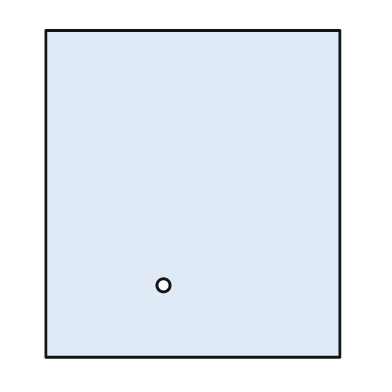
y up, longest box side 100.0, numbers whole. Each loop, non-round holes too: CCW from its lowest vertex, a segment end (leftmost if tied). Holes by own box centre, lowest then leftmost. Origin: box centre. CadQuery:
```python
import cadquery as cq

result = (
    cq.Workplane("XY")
    .moveTo(-45.0, -50.0)
    .lineTo(45.0, -50.0)
    .lineTo(45.0, 50.0)
    .lineTo(-45.0, 50.0)
    .close()
    .moveTo(-9.0, -28.0)
    .circle(2.0)
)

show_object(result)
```